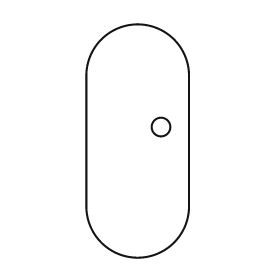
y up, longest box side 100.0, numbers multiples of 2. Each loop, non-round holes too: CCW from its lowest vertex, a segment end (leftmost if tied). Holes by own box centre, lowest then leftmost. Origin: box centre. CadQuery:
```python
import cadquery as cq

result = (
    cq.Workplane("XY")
    .moveTo(-22.0, -28.0)
    .threePointArc((0.0, -50.0), (22.0, -28.0))
    .lineTo(22.0, 28.0)
    .threePointArc((0.0, 50.0), (-22.0, 28.0))
    .close()
    .moveTo(10.0, 6.0)
    .circle(4.0)
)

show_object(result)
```